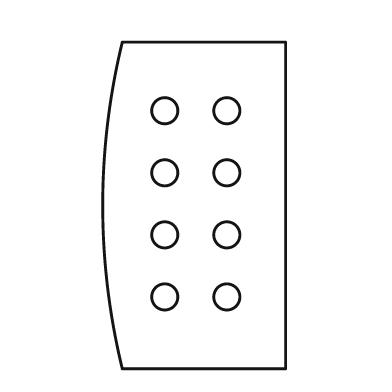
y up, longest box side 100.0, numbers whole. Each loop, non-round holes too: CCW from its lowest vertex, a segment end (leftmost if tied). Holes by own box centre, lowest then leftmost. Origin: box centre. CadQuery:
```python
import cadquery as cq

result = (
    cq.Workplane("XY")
    .moveTo(-22.0, -50.0)
    .lineTo(28.0, -50.0)
    .lineTo(28.0, 50.0)
    .lineTo(-22.0, 50.0)
    .threePointArc((-28.0, 0.0), (-22.0, -50.0))
    .close()
    .moveTo(-9.0, -28.0)
    .circle(4.0)
    .moveTo(10.0, -28.0)
    .circle(4.0)
    .moveTo(-9.0, -9.0)
    .circle(4.0)
    .moveTo(10.0, -9.0)
    .circle(4.0)
    .moveTo(-9.0, 10.0)
    .circle(4.0)
    .moveTo(10.0, 10.0)
    .circle(4.0)
    .moveTo(-9.0, 29.0)
    .circle(4.0)
    .moveTo(10.0, 29.0)
    .circle(4.0)
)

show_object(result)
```